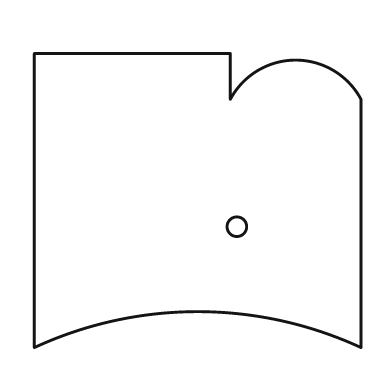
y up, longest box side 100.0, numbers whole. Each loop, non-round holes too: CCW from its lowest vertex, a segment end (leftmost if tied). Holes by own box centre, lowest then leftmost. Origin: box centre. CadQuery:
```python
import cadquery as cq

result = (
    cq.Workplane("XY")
    .moveTo(-50.0, -45.0)
    .threePointArc((0.0, -34.0), (50.0, -45.0))
    .lineTo(50.0, 31.0)
    .threePointArc((30.0, 43.0), (10.0, 31.0))
    .lineTo(10.0, 45.0)
    .lineTo(-50.0, 45.0)
    .close()
    .moveTo(12.0, -8.0)
    .circle(3.0)
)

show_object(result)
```